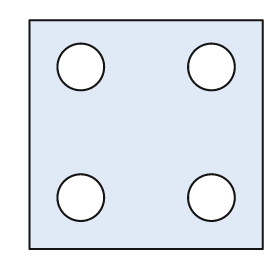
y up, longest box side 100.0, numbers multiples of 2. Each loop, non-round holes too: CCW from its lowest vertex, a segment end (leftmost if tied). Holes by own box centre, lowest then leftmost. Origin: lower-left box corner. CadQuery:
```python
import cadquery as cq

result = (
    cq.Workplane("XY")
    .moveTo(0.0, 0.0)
    .lineTo(100.0, 0.0)
    .lineTo(100.0, 98.0)
    .lineTo(0.0, 98.0)
    .close()
    .moveTo(22.0, 22.0)
    .circle(10.0)
    .moveTo(78.0, 22.0)
    .circle(10.0)
    .moveTo(22.0, 78.0)
    .circle(10.0)
    .moveTo(78.0, 78.0)
    .circle(10.0)
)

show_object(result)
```